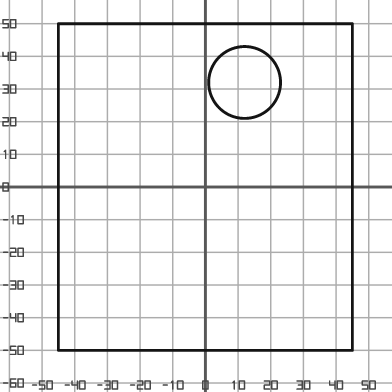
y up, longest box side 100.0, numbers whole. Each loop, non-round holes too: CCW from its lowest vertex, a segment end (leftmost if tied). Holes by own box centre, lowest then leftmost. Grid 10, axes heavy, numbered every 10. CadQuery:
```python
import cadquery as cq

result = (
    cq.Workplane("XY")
    .moveTo(-45.0, -50.0)
    .lineTo(45.0, -50.0)
    .lineTo(45.0, 50.0)
    .lineTo(-45.0, 50.0)
    .close()
    .moveTo(12.0, 32.0)
    .circle(11.0)
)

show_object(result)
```